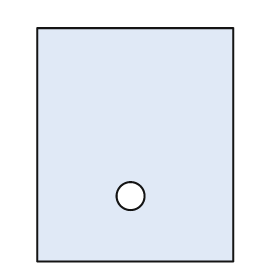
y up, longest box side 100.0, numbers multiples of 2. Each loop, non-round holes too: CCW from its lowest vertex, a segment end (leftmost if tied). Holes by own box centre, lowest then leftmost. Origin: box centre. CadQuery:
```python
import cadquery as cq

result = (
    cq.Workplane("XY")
    .moveTo(-42.0, -50.0)
    .lineTo(42.0, -50.0)
    .lineTo(42.0, 50.0)
    .lineTo(-42.0, 50.0)
    .close()
    .moveTo(-2.0, -22.0)
    .circle(6.0)
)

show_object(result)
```